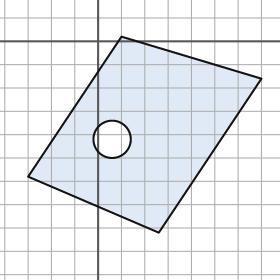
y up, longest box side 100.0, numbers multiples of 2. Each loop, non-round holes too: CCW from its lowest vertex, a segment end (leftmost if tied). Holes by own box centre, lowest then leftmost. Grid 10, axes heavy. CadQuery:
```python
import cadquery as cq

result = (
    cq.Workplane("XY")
    .moveTo(26.0, -82.0)
    .lineTo(70.0, -16.0)
    .lineTo(10.0, 2.0)
    .lineTo(-30.0, -58.0)
    .close()
    .moveTo(6.0, -42.0)
    .circle(8.0)
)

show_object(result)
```